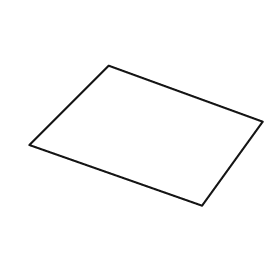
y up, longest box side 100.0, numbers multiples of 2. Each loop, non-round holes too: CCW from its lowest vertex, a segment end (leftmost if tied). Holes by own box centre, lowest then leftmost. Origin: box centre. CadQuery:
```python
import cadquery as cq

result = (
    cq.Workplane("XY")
    .moveTo(24.0, -30.0)
    .lineTo(50.0, 6.0)
    .lineTo(-16.0, 30.0)
    .lineTo(-50.0, -4.0)
    .close()
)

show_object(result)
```